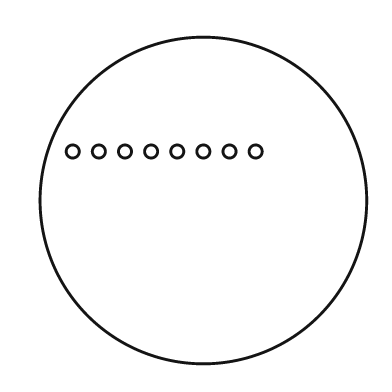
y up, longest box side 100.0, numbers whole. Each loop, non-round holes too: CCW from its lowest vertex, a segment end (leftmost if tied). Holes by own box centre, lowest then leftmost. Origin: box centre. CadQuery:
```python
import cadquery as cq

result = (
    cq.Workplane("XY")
    .moveTo(0.0, 0.0)
    .circle(50.0)
    .moveTo(-40.0, 15.0)
    .circle(2.0)
    .moveTo(-32.0, 15.0)
    .circle(2.0)
    .moveTo(-24.0, 15.0)
    .circle(2.0)
    .moveTo(-16.0, 15.0)
    .circle(2.0)
    .moveTo(-8.0, 15.0)
    .circle(2.0)
    .moveTo(0.0, 15.0)
    .circle(2.0)
    .moveTo(8.0, 15.0)
    .circle(2.0)
    .moveTo(16.0, 15.0)
    .circle(2.0)
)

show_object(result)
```